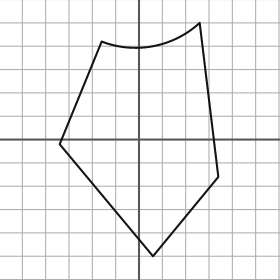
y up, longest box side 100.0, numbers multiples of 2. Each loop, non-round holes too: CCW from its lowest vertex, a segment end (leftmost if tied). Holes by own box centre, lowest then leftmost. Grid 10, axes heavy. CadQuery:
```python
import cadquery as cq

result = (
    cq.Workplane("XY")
    .moveTo(6.0, -50.0)
    .lineTo(34.0, -16.0)
    .lineTo(26.0, 50.0)
    .threePointArc((6.0, 40.0), (-16.0, 42.0))
    .lineTo(-34.0, -2.0)
    .close()
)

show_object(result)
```